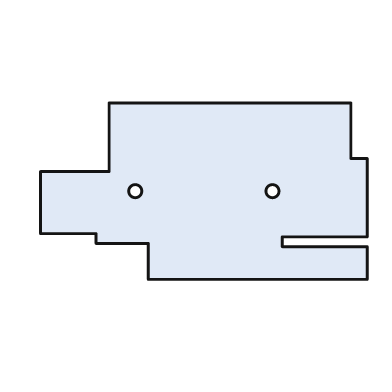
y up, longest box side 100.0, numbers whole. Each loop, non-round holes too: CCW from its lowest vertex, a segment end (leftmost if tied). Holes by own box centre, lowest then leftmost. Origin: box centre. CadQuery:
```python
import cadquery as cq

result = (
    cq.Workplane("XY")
    .moveTo(-17.0, -27.0)
    .lineTo(50.0, -27.0)
    .lineTo(50.0, -17.0)
    .lineTo(24.0, -17.0)
    .lineTo(24.0, -14.0)
    .lineTo(50.0, -14.0)
    .lineTo(50.0, 10.0)
    .lineTo(45.0, 10.0)
    .lineTo(45.0, 27.0)
    .lineTo(-29.0, 27.0)
    .lineTo(-29.0, 6.0)
    .lineTo(-50.0, 6.0)
    .lineTo(-50.0, -13.0)
    .lineTo(-33.0, -13.0)
    .lineTo(-33.0, -16.0)
    .lineTo(-17.0, -16.0)
    .close()
    .moveTo(-21.0, 0.0)
    .circle(2.0)
    .moveTo(21.0, 0.0)
    .circle(2.0)
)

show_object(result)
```